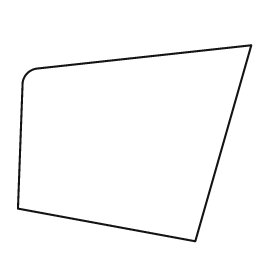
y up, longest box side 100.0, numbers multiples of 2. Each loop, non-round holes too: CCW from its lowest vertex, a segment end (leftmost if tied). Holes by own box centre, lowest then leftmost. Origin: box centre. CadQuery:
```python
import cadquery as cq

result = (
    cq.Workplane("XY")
    .moveTo(26.0, -42.0)
    .lineTo(50.0, 42.0)
    .lineTo(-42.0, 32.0)
    .threePointArc((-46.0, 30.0), (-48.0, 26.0))
    .lineTo(-50.0, -28.0)
    .close()
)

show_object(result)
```